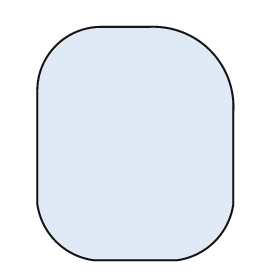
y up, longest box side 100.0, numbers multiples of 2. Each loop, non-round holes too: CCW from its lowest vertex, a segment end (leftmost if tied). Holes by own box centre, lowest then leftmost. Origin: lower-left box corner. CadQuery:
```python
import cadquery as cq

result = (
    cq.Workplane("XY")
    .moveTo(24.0, 0.0)
    .lineTo(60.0, 0.0)
    .threePointArc((76.0, 8.0), (84.0, 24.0))
    .lineTo(84.0, 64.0)
    .threePointArc((74.0, 90.0), (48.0, 100.0))
    .lineTo(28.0, 100.0)
    .threePointArc((8.0, 92.0), (0.0, 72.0))
    .lineTo(0.0, 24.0)
    .threePointArc((8.0, 8.0), (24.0, 0.0))
    .close()
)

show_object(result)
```